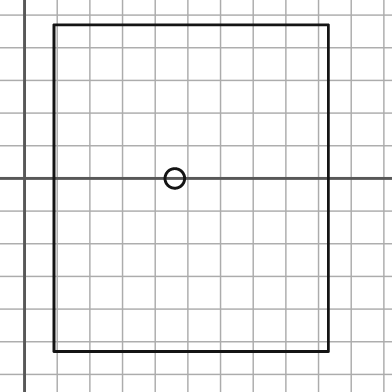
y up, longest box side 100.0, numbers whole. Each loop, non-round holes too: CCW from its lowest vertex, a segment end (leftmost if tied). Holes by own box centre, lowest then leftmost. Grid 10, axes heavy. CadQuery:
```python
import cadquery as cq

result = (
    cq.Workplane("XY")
    .moveTo(9.0, -53.0)
    .lineTo(93.0, -53.0)
    .lineTo(93.0, 47.0)
    .lineTo(9.0, 47.0)
    .close()
    .moveTo(46.0, 0.0)
    .circle(3.0)
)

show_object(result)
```